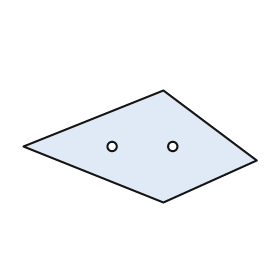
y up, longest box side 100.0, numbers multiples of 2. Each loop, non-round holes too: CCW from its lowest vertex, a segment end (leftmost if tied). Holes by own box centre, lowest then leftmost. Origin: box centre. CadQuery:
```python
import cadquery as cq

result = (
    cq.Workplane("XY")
    .moveTo(10.0, -24.0)
    .lineTo(50.0, -6.0)
    .lineTo(10.0, 24.0)
    .lineTo(-50.0, 0.0)
    .close()
    .moveTo(-12.0, 0.0)
    .circle(2.0)
    .moveTo(14.0, 0.0)
    .circle(2.0)
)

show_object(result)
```